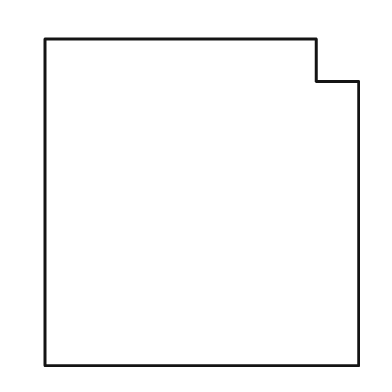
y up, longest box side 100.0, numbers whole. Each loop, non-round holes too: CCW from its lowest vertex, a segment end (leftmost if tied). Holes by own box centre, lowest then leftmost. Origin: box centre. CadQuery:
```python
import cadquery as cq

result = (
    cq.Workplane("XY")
    .moveTo(-48.0, -50.0)
    .lineTo(48.0, -50.0)
    .lineTo(48.0, 37.0)
    .lineTo(35.0, 37.0)
    .lineTo(35.0, 50.0)
    .lineTo(-48.0, 50.0)
    .close()
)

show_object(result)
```